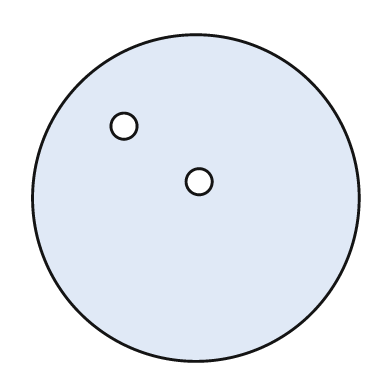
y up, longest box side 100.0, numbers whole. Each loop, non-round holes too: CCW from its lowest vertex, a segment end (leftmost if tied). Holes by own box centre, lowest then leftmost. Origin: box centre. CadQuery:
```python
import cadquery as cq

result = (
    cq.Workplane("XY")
    .moveTo(0.0, 0.0)
    .circle(50.0)
    .moveTo(1.0, 5.0)
    .circle(4.0)
    .moveTo(-22.0, 22.0)
    .circle(4.0)
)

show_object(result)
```